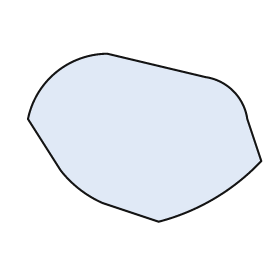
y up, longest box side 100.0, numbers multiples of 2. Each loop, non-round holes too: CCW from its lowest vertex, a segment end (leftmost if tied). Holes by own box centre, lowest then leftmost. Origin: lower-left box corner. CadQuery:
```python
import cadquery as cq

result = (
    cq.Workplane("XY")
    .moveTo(56.0, 0.0)
    .threePointArc((80.0, 10.0), (100.0, 26.0))
    .lineTo(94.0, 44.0)
    .threePointArc((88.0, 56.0), (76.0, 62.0))
    .lineTo(34.0, 72.0)
    .threePointArc((12.0, 64.0), (0.0, 44.0))
    .lineTo(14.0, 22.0)
    .threePointArc((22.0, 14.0), (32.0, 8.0))
    .close()
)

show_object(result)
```